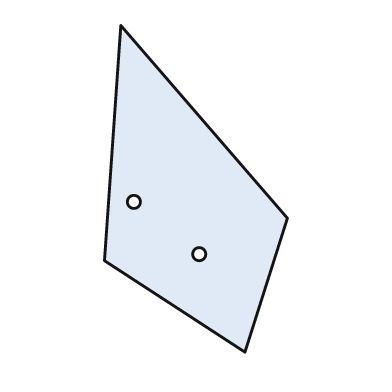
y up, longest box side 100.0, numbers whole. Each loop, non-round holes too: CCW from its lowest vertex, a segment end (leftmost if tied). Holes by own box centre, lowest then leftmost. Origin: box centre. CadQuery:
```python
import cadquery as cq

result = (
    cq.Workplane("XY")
    .moveTo(15.0, -50.0)
    .lineTo(28.0, -9.0)
    .lineTo(-23.0, 50.0)
    .lineTo(-28.0, -22.0)
    .close()
    .moveTo(1.0, -20.0)
    .circle(2.0)
    .moveTo(-19.0, -4.0)
    .circle(2.0)
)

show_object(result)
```